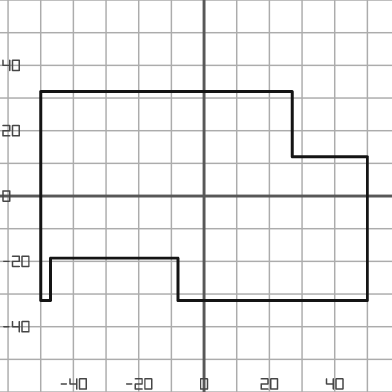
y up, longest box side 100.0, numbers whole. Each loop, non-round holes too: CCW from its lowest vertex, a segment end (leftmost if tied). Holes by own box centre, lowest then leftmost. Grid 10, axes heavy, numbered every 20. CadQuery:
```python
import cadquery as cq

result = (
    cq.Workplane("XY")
    .moveTo(-50.0, -32.0)
    .lineTo(-47.0, -32.0)
    .lineTo(-47.0, -19.0)
    .lineTo(-8.0, -19.0)
    .lineTo(-8.0, -32.0)
    .lineTo(50.0, -32.0)
    .lineTo(50.0, 12.0)
    .lineTo(27.0, 12.0)
    .lineTo(27.0, 32.0)
    .lineTo(-50.0, 32.0)
    .close()
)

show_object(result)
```